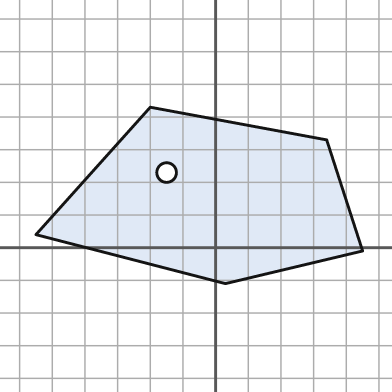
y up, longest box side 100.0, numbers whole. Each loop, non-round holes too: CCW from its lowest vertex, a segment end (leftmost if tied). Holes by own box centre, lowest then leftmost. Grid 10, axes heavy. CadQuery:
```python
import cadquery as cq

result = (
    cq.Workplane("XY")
    .moveTo(3.0, -11.0)
    .lineTo(45.0, -1.0)
    .lineTo(34.0, 33.0)
    .lineTo(-20.0, 43.0)
    .lineTo(-55.0, 4.0)
    .close()
    .moveTo(-15.0, 23.0)
    .circle(3.0)
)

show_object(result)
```